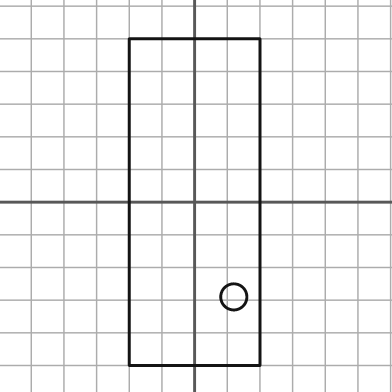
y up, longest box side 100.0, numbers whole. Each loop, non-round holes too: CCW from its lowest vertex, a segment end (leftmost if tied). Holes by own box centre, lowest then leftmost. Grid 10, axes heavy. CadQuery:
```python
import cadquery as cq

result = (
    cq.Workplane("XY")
    .moveTo(-20.0, -50.0)
    .lineTo(20.0, -50.0)
    .lineTo(20.0, 50.0)
    .lineTo(-20.0, 50.0)
    .close()
    .moveTo(12.0, -29.0)
    .circle(4.0)
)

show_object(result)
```